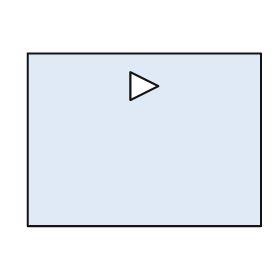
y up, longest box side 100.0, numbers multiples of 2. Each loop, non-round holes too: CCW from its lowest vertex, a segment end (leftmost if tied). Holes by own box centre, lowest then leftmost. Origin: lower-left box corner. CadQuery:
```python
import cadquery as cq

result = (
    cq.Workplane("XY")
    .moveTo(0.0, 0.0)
    .lineTo(100.0, 0.0)
    .lineTo(100.0, 74.0)
    .lineTo(0.0, 74.0)
    .close()
    .moveTo(44.0, 54.0)
    .lineTo(56.0, 60.0)
    .lineTo(44.0, 66.0)
    .close()
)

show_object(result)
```